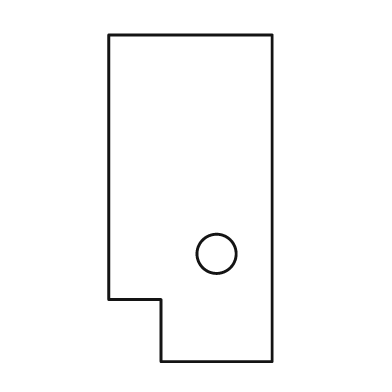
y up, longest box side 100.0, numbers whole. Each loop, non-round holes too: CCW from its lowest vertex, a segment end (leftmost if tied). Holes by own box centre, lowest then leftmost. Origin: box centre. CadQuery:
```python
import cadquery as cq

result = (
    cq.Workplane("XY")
    .moveTo(-9.0, -50.0)
    .lineTo(25.0, -50.0)
    .lineTo(25.0, 50.0)
    .lineTo(-25.0, 50.0)
    .lineTo(-25.0, -31.0)
    .lineTo(-9.0, -31.0)
    .close()
    .moveTo(8.0, -17.0)
    .circle(6.0)
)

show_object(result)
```